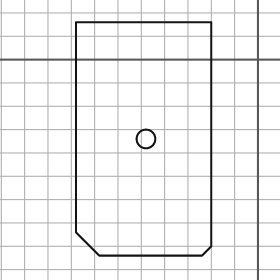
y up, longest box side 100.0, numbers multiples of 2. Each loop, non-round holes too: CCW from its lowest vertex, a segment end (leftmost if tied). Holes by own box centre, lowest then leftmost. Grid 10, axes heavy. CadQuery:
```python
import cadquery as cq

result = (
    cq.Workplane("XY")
    .moveTo(-68.0, -84.0)
    .lineTo(-24.0, -84.0)
    .lineTo(-20.0, -80.0)
    .lineTo(-20.0, 16.0)
    .lineTo(-78.0, 16.0)
    .lineTo(-78.0, -74.0)
    .close()
    .moveTo(-48.0, -34.0)
    .circle(4.0)
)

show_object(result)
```